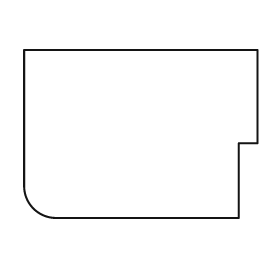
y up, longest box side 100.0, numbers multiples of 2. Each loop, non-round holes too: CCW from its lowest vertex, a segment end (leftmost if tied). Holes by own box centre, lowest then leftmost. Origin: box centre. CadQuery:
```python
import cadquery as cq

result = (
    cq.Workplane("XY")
    .moveTo(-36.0, -36.0)
    .lineTo(42.0, -36.0)
    .lineTo(42.0, -4.0)
    .lineTo(50.0, -4.0)
    .lineTo(50.0, 36.0)
    .lineTo(-50.0, 36.0)
    .lineTo(-50.0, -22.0)
    .threePointArc((-46.0, -32.0), (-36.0, -36.0))
    .close()
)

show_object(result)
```